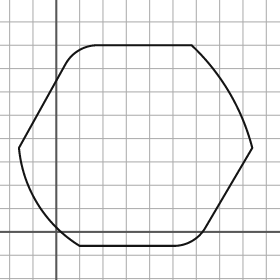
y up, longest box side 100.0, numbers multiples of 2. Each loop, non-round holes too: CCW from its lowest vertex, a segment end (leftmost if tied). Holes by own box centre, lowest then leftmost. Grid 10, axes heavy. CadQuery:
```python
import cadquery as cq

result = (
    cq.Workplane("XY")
    .moveTo(10.0, -6.0)
    .lineTo(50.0, -6.0)
    .threePointArc((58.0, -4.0), (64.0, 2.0))
    .lineTo(84.0, 36.0)
    .threePointArc((74.0, 60.0), (58.0, 80.0))
    .lineTo(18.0, 80.0)
    .threePointArc((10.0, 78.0), (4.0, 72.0))
    .lineTo(-16.0, 36.0)
    .threePointArc((-8.0, 12.0), (10.0, -6.0))
    .close()
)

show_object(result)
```